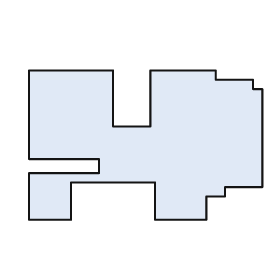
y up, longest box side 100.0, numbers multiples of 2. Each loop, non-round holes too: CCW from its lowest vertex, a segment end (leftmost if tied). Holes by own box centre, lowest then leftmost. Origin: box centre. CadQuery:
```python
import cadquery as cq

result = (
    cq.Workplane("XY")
    .moveTo(-50.0, -32.0)
    .lineTo(-32.0, -32.0)
    .lineTo(-32.0, -16.0)
    .lineTo(4.0, -16.0)
    .lineTo(4.0, -32.0)
    .lineTo(26.0, -32.0)
    .lineTo(26.0, -22.0)
    .lineTo(34.0, -22.0)
    .lineTo(34.0, -18.0)
    .lineTo(50.0, -18.0)
    .lineTo(50.0, 24.0)
    .lineTo(46.0, 24.0)
    .lineTo(46.0, 28.0)
    .lineTo(30.0, 28.0)
    .lineTo(30.0, 32.0)
    .lineTo(2.0, 32.0)
    .lineTo(2.0, 8.0)
    .lineTo(-14.0, 8.0)
    .lineTo(-14.0, 32.0)
    .lineTo(-50.0, 32.0)
    .lineTo(-50.0, -6.0)
    .lineTo(-20.0, -6.0)
    .lineTo(-20.0, -12.0)
    .lineTo(-50.0, -12.0)
    .close()
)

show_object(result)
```